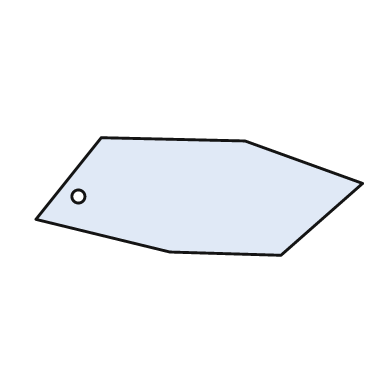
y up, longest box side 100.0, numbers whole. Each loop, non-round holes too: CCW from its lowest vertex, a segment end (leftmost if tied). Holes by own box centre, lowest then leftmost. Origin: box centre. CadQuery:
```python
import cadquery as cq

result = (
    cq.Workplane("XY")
    .moveTo(25.0, -18.0)
    .lineTo(50.0, 4.0)
    .lineTo(14.0, 17.0)
    .lineTo(-30.0, 18.0)
    .lineTo(-50.0, -7.0)
    .lineTo(-9.0, -17.0)
    .close()
    .moveTo(-37.0, 0.0)
    .circle(2.0)
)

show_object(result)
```